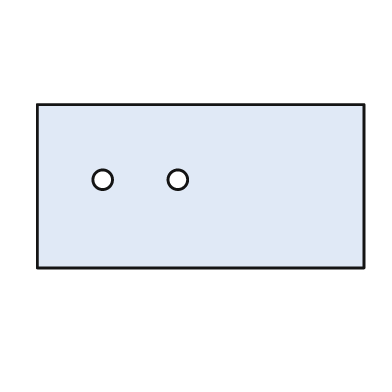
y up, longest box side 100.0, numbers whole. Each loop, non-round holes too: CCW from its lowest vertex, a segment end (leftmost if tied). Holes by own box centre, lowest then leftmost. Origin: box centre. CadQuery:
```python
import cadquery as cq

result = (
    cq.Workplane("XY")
    .moveTo(-50.0, -25.0)
    .lineTo(50.0, -25.0)
    .lineTo(50.0, 25.0)
    .lineTo(-50.0, 25.0)
    .close()
    .moveTo(-30.0, 2.0)
    .circle(3.0)
    .moveTo(-7.0, 2.0)
    .circle(3.0)
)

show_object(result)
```